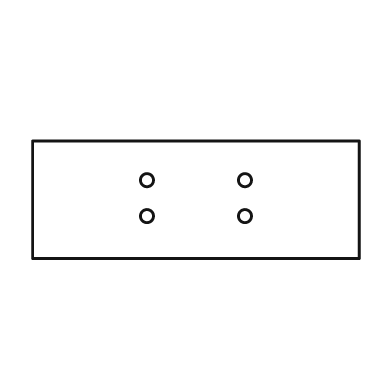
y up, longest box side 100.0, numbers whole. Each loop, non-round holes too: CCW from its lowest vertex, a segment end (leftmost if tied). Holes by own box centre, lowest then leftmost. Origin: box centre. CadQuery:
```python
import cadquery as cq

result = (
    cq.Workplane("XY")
    .moveTo(-50.0, -18.0)
    .lineTo(50.0, -18.0)
    .lineTo(50.0, 18.0)
    .lineTo(-50.0, 18.0)
    .close()
    .moveTo(-15.0, -5.0)
    .circle(2.0)
    .moveTo(15.0, -5.0)
    .circle(2.0)
    .moveTo(-15.0, 6.0)
    .circle(2.0)
    .moveTo(15.0, 6.0)
    .circle(2.0)
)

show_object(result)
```